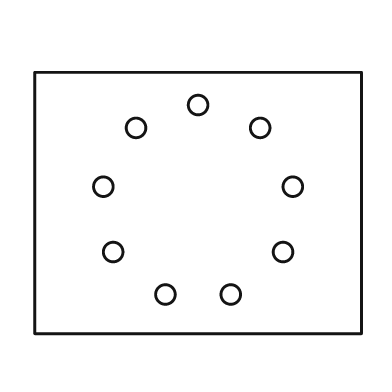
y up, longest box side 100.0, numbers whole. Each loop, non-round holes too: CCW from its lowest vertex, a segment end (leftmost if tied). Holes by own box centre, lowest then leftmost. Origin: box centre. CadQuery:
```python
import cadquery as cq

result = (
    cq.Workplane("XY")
    .moveTo(-50.0, -40.0)
    .lineTo(50.0, -40.0)
    .lineTo(50.0, 40.0)
    .lineTo(-50.0, 40.0)
    .close()
    .moveTo(-10.0, -28.0)
    .circle(3.0)
    .moveTo(10.0, -28.0)
    .circle(3.0)
    .moveTo(-26.0, -15.0)
    .circle(3.0)
    .moveTo(26.0, -15.0)
    .circle(3.0)
    .moveTo(-29.0, 5.0)
    .circle(3.0)
    .moveTo(29.0, 5.0)
    .circle(3.0)
    .moveTo(-19.0, 23.0)
    .circle(3.0)
    .moveTo(19.0, 23.0)
    .circle(3.0)
    .moveTo(0.0, 30.0)
    .circle(3.0)
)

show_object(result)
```